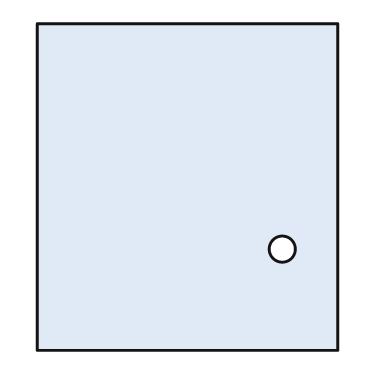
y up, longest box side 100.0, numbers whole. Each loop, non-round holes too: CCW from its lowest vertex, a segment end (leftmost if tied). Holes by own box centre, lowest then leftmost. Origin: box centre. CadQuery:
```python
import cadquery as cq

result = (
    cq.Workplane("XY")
    .moveTo(-46.0, -50.0)
    .lineTo(46.0, -50.0)
    .lineTo(46.0, 50.0)
    .lineTo(-46.0, 50.0)
    .close()
    .moveTo(29.0, -19.0)
    .circle(4.0)
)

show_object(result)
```